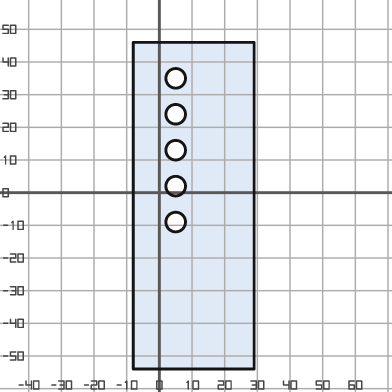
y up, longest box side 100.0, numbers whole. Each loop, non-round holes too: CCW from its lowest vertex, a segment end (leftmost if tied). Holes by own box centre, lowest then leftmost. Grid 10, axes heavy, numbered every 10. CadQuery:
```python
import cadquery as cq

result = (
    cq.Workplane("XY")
    .moveTo(-8.0, -54.0)
    .lineTo(29.0, -54.0)
    .lineTo(29.0, 46.0)
    .lineTo(-8.0, 46.0)
    .close()
    .moveTo(5.0, -9.0)
    .circle(3.0)
    .moveTo(5.0, 2.0)
    .circle(3.0)
    .moveTo(5.0, 13.0)
    .circle(3.0)
    .moveTo(5.0, 24.0)
    .circle(3.0)
    .moveTo(5.0, 35.0)
    .circle(3.0)
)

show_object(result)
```